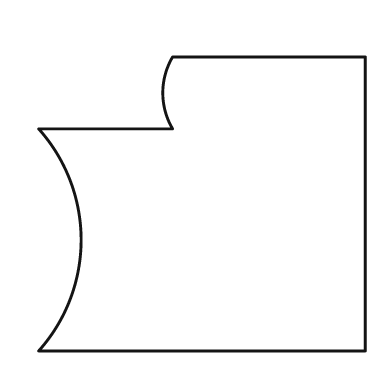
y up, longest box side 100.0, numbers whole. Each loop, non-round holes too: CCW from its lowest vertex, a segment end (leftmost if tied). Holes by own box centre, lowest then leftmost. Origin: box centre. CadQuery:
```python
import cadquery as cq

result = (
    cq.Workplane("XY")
    .moveTo(-50.0, -45.0)
    .lineTo(50.0, -45.0)
    .lineTo(50.0, 45.0)
    .lineTo(-9.0, 45.0)
    .threePointArc((-12.0, 34.0), (-9.0, 23.0))
    .lineTo(-50.0, 23.0)
    .threePointArc((-37.0, -11.0), (-50.0, -45.0))
    .close()
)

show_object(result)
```